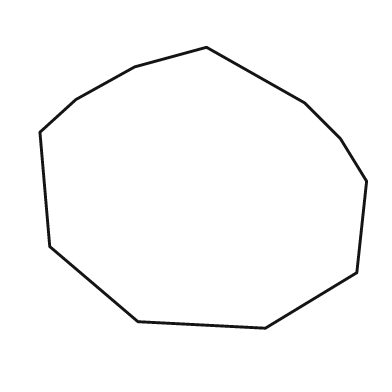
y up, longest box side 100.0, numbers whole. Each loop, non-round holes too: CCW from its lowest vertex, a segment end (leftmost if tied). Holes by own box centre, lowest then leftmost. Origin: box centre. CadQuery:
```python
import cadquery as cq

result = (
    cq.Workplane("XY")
    .moveTo(19.0, -43.0)
    .lineTo(47.0, -26.0)
    .lineTo(50.0, 2.0)
    .lineTo(42.0, 15.0)
    .lineTo(31.0, 26.0)
    .lineTo(1.0, 43.0)
    .lineTo(-21.0, 37.0)
    .lineTo(-39.0, 27.0)
    .lineTo(-50.0, 17.0)
    .lineTo(-47.0, -18.0)
    .lineTo(-20.0, -41.0)
    .close()
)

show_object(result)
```